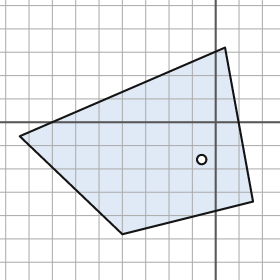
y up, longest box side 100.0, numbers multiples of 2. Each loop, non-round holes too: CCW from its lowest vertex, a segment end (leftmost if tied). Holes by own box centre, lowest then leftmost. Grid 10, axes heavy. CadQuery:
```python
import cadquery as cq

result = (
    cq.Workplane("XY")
    .moveTo(-40.0, -48.0)
    .lineTo(16.0, -34.0)
    .lineTo(4.0, 32.0)
    .lineTo(-84.0, -6.0)
    .close()
    .moveTo(-6.0, -16.0)
    .circle(2.0)
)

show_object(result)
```